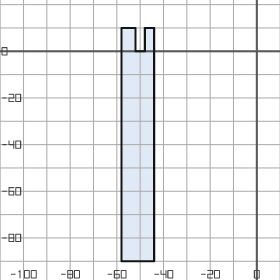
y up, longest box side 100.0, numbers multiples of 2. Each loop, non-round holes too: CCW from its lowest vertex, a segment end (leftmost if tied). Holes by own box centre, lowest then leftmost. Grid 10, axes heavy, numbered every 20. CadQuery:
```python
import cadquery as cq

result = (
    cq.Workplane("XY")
    .moveTo(-58.0, -90.0)
    .lineTo(-44.0, -90.0)
    .lineTo(-44.0, 10.0)
    .lineTo(-48.0, 10.0)
    .lineTo(-48.0, 0.0)
    .lineTo(-52.0, 0.0)
    .lineTo(-52.0, 10.0)
    .lineTo(-58.0, 10.0)
    .close()
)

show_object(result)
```